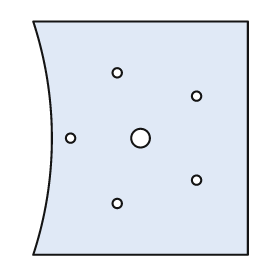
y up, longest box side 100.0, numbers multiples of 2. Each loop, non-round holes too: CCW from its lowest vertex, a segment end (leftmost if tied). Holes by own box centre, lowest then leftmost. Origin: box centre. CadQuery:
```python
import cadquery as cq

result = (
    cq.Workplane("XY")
    .moveTo(-46.0, -50.0)
    .lineTo(46.0, -50.0)
    .lineTo(46.0, 50.0)
    .lineTo(-46.0, 50.0)
    .threePointArc((-38.0, 0.0), (-46.0, -50.0))
    .close()
    .moveTo(-10.0, -28.0)
    .circle(2.0)
    .moveTo(24.0, -18.0)
    .circle(2.0)
    .moveTo(-30.0, 0.0)
    .circle(2.0)
    .moveTo(0.0, 0.0)
    .circle(4.0)
    .moveTo(24.0, 18.0)
    .circle(2.0)
    .moveTo(-10.0, 28.0)
    .circle(2.0)
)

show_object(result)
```